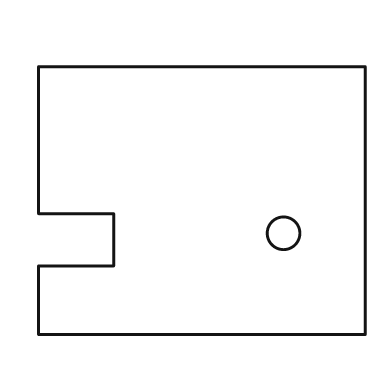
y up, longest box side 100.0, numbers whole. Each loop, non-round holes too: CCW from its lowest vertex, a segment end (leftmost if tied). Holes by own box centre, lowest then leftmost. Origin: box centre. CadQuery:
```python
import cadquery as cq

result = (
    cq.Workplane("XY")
    .moveTo(-50.0, -41.0)
    .lineTo(50.0, -41.0)
    .lineTo(50.0, 41.0)
    .lineTo(-50.0, 41.0)
    .lineTo(-50.0, -4.0)
    .lineTo(-27.0, -4.0)
    .lineTo(-27.0, -20.0)
    .lineTo(-50.0, -20.0)
    .close()
    .moveTo(25.0, -10.0)
    .circle(5.0)
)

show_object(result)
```